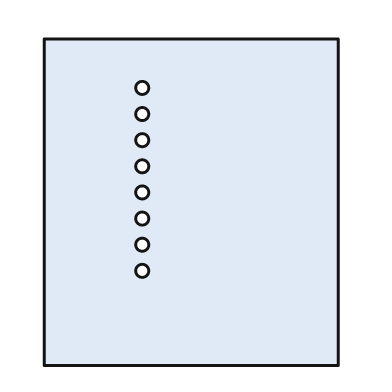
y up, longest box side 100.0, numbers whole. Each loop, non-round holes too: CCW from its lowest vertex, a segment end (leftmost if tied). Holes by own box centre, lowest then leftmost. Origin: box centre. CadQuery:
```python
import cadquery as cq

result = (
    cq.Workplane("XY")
    .moveTo(-45.0, -50.0)
    .lineTo(45.0, -50.0)
    .lineTo(45.0, 50.0)
    .lineTo(-45.0, 50.0)
    .close()
    .moveTo(-15.0, -21.0)
    .circle(2.0)
    .moveTo(-15.0, -13.0)
    .circle(2.0)
    .moveTo(-15.0, -5.0)
    .circle(2.0)
    .moveTo(-15.0, 3.0)
    .circle(2.0)
    .moveTo(-15.0, 11.0)
    .circle(2.0)
    .moveTo(-15.0, 19.0)
    .circle(2.0)
    .moveTo(-15.0, 27.0)
    .circle(2.0)
    .moveTo(-15.0, 35.0)
    .circle(2.0)
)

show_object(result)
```